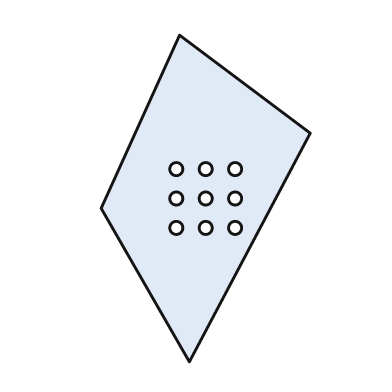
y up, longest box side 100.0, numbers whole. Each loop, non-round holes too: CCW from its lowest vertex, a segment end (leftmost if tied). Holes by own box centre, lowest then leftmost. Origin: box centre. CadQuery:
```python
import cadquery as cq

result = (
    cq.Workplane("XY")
    .moveTo(-5.0, -50.0)
    .lineTo(32.0, 20.0)
    .lineTo(-8.0, 50.0)
    .lineTo(-32.0, -3.0)
    .close()
    .moveTo(-9.0, -9.0)
    .circle(2.0)
    .moveTo(0.0, -9.0)
    .circle(2.0)
    .moveTo(9.0, -9.0)
    .circle(2.0)
    .moveTo(-9.0, 0.0)
    .circle(2.0)
    .moveTo(0.0, 0.0)
    .circle(2.0)
    .moveTo(9.0, 0.0)
    .circle(2.0)
    .moveTo(-9.0, 9.0)
    .circle(2.0)
    .moveTo(0.0, 9.0)
    .circle(2.0)
    .moveTo(9.0, 9.0)
    .circle(2.0)
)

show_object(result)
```